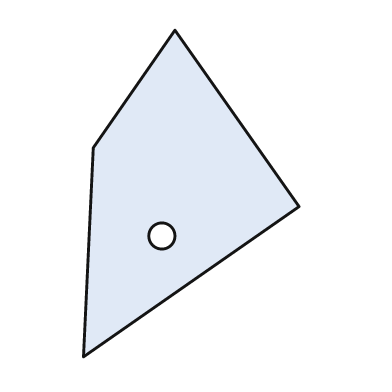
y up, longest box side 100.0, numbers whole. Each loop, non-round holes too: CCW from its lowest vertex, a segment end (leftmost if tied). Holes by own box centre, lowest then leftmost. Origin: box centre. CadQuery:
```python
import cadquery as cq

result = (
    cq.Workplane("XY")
    .moveTo(-33.0, -50.0)
    .lineTo(33.0, -4.0)
    .lineTo(-5.0, 50.0)
    .lineTo(-30.0, 14.0)
    .close()
    .moveTo(-9.0, -13.0)
    .circle(4.0)
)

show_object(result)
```